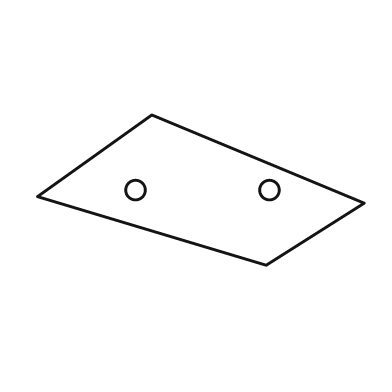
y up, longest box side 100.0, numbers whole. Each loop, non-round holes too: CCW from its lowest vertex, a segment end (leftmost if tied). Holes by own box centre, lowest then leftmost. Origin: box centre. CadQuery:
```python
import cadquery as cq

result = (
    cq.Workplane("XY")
    .moveTo(20.0, -23.0)
    .lineTo(50.0, -4.0)
    .lineTo(-15.0, 23.0)
    .lineTo(-50.0, -2.0)
    .close()
    .moveTo(-20.0, 0.0)
    .circle(3.0)
    .moveTo(21.0, 0.0)
    .circle(3.0)
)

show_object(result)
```